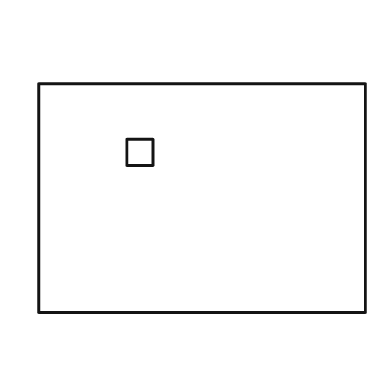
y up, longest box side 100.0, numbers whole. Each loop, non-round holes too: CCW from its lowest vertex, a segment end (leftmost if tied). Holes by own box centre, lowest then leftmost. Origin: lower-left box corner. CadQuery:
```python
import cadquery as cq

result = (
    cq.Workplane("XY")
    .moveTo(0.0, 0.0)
    .lineTo(100.0, 0.0)
    .lineTo(100.0, 70.0)
    .lineTo(0.0, 70.0)
    .close()
    .moveTo(27.0, 45.0)
    .lineTo(35.0, 45.0)
    .lineTo(35.0, 53.0)
    .lineTo(27.0, 53.0)
    .close()
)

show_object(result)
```